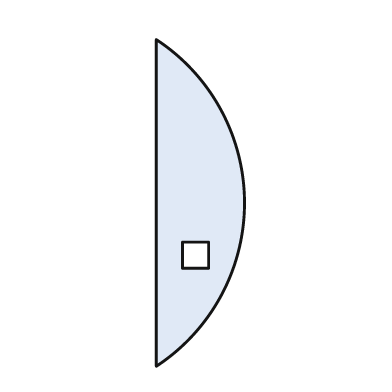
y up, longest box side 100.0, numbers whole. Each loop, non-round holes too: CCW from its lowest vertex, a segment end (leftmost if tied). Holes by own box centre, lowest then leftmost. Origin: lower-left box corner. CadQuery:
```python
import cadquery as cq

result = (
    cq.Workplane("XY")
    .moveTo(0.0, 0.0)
    .threePointArc((27.0, 50.0), (0.0, 100.0))
    .close()
    .moveTo(8.0, 30.0)
    .lineTo(16.0, 30.0)
    .lineTo(16.0, 38.0)
    .lineTo(8.0, 38.0)
    .close()
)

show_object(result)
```